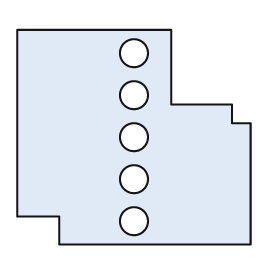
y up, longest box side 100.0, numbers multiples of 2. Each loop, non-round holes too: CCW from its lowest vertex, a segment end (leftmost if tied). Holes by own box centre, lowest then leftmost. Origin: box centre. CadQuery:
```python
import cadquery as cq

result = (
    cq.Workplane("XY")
    .moveTo(-32.0, -46.0)
    .lineTo(50.0, -46.0)
    .lineTo(50.0, 6.0)
    .lineTo(42.0, 6.0)
    .lineTo(42.0, 14.0)
    .lineTo(16.0, 14.0)
    .lineTo(16.0, 46.0)
    .lineTo(-50.0, 46.0)
    .lineTo(-50.0, -34.0)
    .lineTo(-32.0, -34.0)
    .close()
    .moveTo(0.0, -36.0)
    .circle(6.0)
    .moveTo(0.0, -18.0)
    .circle(6.0)
    .moveTo(0.0, 0.0)
    .circle(6.0)
    .moveTo(0.0, 18.0)
    .circle(6.0)
    .moveTo(0.0, 36.0)
    .circle(6.0)
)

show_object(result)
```